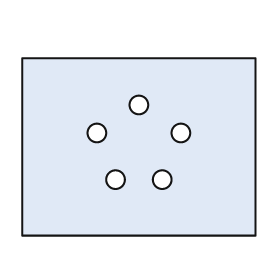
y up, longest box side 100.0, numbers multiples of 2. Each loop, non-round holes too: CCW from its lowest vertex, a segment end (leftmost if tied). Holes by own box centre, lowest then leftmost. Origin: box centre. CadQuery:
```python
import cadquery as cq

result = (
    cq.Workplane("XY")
    .moveTo(-50.0, -38.0)
    .lineTo(50.0, -38.0)
    .lineTo(50.0, 38.0)
    .lineTo(-50.0, 38.0)
    .close()
    .moveTo(-10.0, -14.0)
    .circle(4.0)
    .moveTo(10.0, -14.0)
    .circle(4.0)
    .moveTo(-18.0, 6.0)
    .circle(4.0)
    .moveTo(18.0, 6.0)
    .circle(4.0)
    .moveTo(0.0, 18.0)
    .circle(4.0)
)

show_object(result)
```